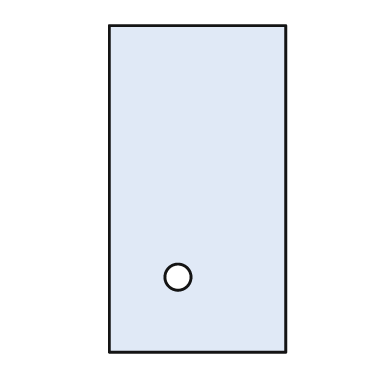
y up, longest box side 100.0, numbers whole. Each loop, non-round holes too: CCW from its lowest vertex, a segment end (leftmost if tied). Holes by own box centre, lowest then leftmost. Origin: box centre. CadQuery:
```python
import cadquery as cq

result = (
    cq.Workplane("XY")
    .moveTo(-27.0, -50.0)
    .lineTo(27.0, -50.0)
    .lineTo(27.0, 50.0)
    .lineTo(-27.0, 50.0)
    .close()
    .moveTo(-6.0, -27.0)
    .circle(4.0)
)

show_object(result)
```